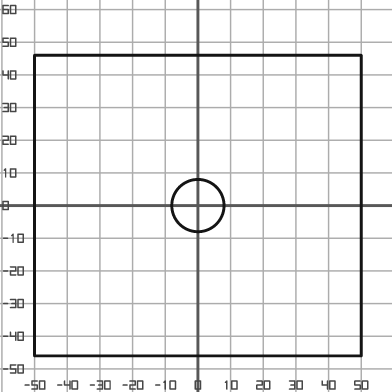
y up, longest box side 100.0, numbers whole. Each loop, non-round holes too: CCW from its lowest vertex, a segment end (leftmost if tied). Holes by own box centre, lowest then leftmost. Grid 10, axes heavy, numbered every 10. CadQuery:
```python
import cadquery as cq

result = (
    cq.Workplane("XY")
    .moveTo(-50.0, -46.0)
    .lineTo(50.0, -46.0)
    .lineTo(50.0, 46.0)
    .lineTo(-50.0, 46.0)
    .close()
    .moveTo(0.0, 0.0)
    .circle(8.0)
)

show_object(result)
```